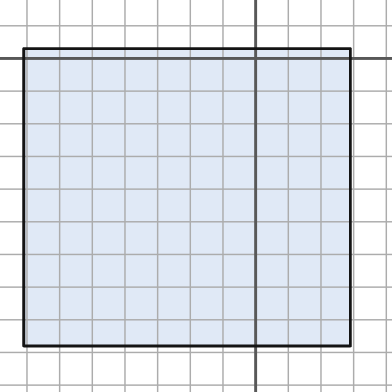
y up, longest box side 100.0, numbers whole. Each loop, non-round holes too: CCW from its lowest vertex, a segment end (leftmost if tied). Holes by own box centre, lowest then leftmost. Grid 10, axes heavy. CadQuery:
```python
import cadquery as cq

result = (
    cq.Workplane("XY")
    .moveTo(-71.0, -88.0)
    .lineTo(29.0, -88.0)
    .lineTo(29.0, 3.0)
    .lineTo(-71.0, 3.0)
    .close()
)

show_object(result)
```